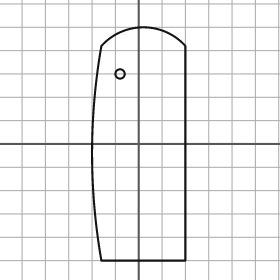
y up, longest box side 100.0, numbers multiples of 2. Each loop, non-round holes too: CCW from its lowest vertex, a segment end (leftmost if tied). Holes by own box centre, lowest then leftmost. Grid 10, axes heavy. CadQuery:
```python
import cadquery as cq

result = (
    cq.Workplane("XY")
    .moveTo(-16.0, -50.0)
    .lineTo(20.0, -50.0)
    .lineTo(20.0, 42.0)
    .threePointArc((2.0, 50.0), (-16.0, 42.0))
    .threePointArc((-20.0, -4.0), (-16.0, -50.0))
    .close()
    .moveTo(-8.0, 30.0)
    .circle(2.0)
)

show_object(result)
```